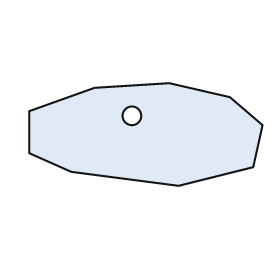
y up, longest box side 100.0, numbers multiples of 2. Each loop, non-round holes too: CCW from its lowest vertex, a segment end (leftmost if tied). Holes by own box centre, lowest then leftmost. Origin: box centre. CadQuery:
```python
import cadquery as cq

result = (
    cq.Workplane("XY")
    .moveTo(14.0, -22.0)
    .lineTo(46.0, -14.0)
    .lineTo(50.0, 4.0)
    .lineTo(36.0, 16.0)
    .lineTo(10.0, 22.0)
    .lineTo(-22.0, 20.0)
    .lineTo(-50.0, 10.0)
    .lineTo(-50.0, -8.0)
    .lineTo(-32.0, -16.0)
    .close()
    .moveTo(-6.0, 8.0)
    .circle(4.0)
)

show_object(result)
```